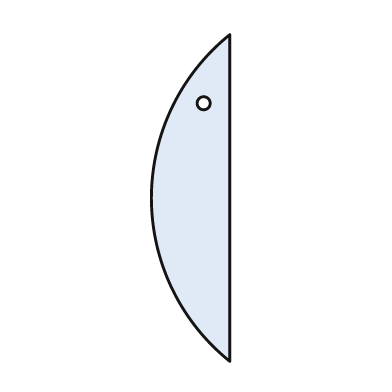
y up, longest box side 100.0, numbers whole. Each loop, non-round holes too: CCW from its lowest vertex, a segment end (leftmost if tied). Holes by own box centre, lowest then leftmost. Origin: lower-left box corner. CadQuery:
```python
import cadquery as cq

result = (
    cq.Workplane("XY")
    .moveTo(24.0, 0.0)
    .lineTo(24.0, 100.0)
    .threePointArc((0.0, 50.0), (24.0, 0.0))
    .close()
    .moveTo(16.0, 79.0)
    .circle(2.0)
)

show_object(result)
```